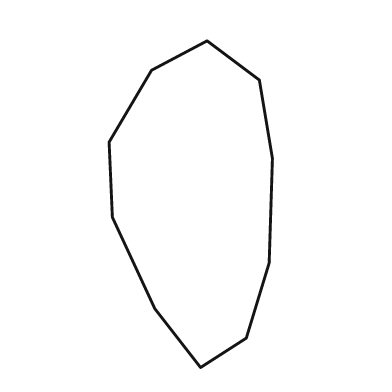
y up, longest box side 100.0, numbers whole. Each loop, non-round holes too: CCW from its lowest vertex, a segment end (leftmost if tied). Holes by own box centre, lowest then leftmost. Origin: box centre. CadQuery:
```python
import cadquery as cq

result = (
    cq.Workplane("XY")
    .moveTo(3.0, -50.0)
    .lineTo(17.0, -41.0)
    .lineTo(24.0, -18.0)
    .lineTo(25.0, 14.0)
    .lineTo(21.0, 38.0)
    .lineTo(5.0, 50.0)
    .lineTo(-12.0, 41.0)
    .lineTo(-25.0, 19.0)
    .lineTo(-24.0, -4.0)
    .lineTo(-11.0, -32.0)
    .close()
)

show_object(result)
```